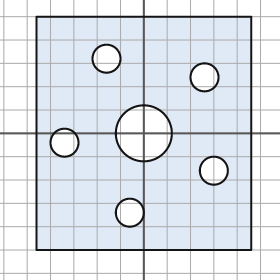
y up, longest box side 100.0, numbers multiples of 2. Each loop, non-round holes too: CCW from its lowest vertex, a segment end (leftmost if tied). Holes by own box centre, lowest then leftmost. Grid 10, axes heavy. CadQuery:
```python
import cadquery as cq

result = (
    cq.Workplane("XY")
    .moveTo(-46.0, -50.0)
    .lineTo(46.0, -50.0)
    .lineTo(46.0, 50.0)
    .lineTo(-46.0, 50.0)
    .close()
    .moveTo(-6.0, -34.0)
    .circle(6.0)
    .moveTo(30.0, -16.0)
    .circle(6.0)
    .moveTo(-34.0, -4.0)
    .circle(6.0)
    .moveTo(0.0, 0.0)
    .circle(12.0)
    .moveTo(26.0, 24.0)
    .circle(6.0)
    .moveTo(-16.0, 32.0)
    .circle(6.0)
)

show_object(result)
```